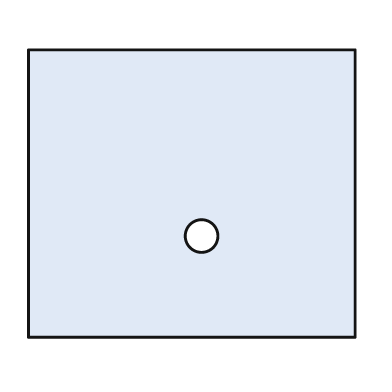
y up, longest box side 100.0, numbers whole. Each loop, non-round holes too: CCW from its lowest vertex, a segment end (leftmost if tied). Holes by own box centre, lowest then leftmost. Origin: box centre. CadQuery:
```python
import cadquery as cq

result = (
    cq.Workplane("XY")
    .moveTo(-50.0, -44.0)
    .lineTo(50.0, -44.0)
    .lineTo(50.0, 44.0)
    .lineTo(-50.0, 44.0)
    .close()
    .moveTo(3.0, -13.0)
    .circle(5.0)
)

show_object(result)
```